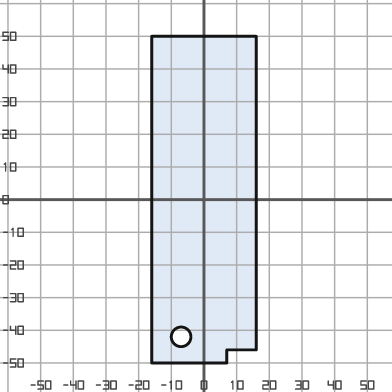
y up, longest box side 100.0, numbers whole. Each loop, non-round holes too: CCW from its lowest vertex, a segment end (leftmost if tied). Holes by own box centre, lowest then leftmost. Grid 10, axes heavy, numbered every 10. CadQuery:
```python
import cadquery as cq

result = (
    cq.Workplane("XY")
    .moveTo(-16.0, -50.0)
    .lineTo(7.0, -50.0)
    .lineTo(7.0, -46.0)
    .lineTo(16.0, -46.0)
    .lineTo(16.0, 50.0)
    .lineTo(-16.0, 50.0)
    .close()
    .moveTo(-7.0, -42.0)
    .circle(3.0)
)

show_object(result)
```